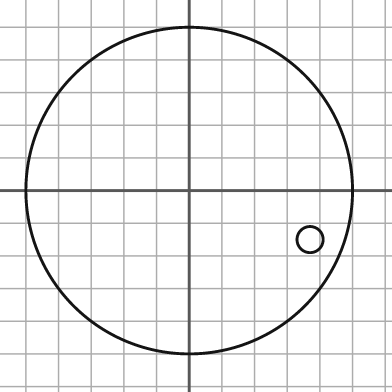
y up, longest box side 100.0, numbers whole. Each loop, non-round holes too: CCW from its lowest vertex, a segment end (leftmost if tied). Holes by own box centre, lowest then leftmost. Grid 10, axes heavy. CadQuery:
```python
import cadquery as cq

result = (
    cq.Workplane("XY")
    .moveTo(0.0, 0.0)
    .circle(50.0)
    .moveTo(37.0, -15.0)
    .circle(4.0)
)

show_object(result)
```